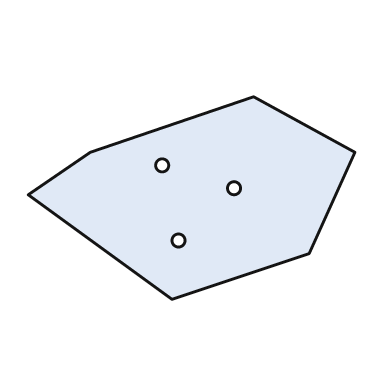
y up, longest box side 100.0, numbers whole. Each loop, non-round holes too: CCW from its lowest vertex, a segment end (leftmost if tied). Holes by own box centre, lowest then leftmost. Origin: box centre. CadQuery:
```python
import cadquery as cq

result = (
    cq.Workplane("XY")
    .moveTo(-6.0, -31.0)
    .lineTo(36.0, -17.0)
    .lineTo(50.0, 14.0)
    .lineTo(19.0, 31.0)
    .lineTo(-31.0, 14.0)
    .lineTo(-50.0, 1.0)
    .close()
    .moveTo(-4.0, -13.0)
    .circle(2.0)
    .moveTo(13.0, 3.0)
    .circle(2.0)
    .moveTo(-9.0, 10.0)
    .circle(2.0)
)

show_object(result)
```